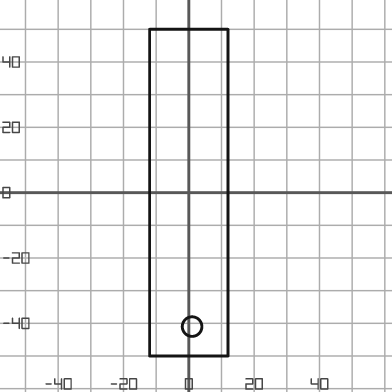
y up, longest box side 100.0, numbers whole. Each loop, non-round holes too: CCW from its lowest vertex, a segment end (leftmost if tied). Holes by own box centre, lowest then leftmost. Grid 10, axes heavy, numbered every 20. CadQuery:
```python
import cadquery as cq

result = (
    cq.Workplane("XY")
    .moveTo(-12.0, -50.0)
    .lineTo(12.0, -50.0)
    .lineTo(12.0, 50.0)
    .lineTo(-12.0, 50.0)
    .close()
    .moveTo(1.0, -41.0)
    .circle(3.0)
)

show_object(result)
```